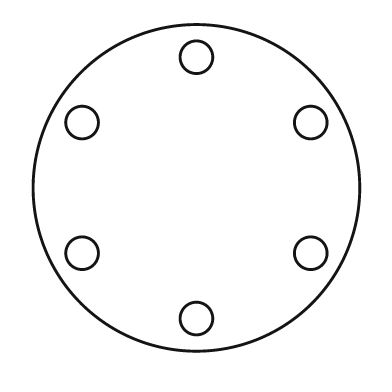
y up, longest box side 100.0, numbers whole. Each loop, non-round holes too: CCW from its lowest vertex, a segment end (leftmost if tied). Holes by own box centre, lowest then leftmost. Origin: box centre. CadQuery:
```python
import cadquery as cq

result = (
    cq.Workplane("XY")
    .moveTo(0.0, 0.0)
    .circle(50.0)
    .moveTo(0.0, -40.0)
    .circle(5.0)
    .moveTo(-35.0, -20.0)
    .circle(5.0)
    .moveTo(35.0, -20.0)
    .circle(5.0)
    .moveTo(-35.0, 20.0)
    .circle(5.0)
    .moveTo(35.0, 20.0)
    .circle(5.0)
    .moveTo(0.0, 40.0)
    .circle(5.0)
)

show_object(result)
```